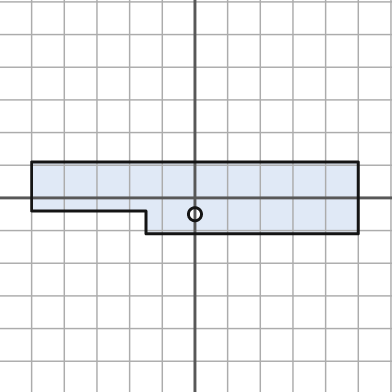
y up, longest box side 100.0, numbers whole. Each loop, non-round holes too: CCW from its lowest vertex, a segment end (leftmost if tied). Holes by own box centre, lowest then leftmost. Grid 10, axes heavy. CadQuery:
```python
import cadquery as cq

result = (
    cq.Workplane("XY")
    .moveTo(-15.0, -11.0)
    .lineTo(50.0, -11.0)
    .lineTo(50.0, 11.0)
    .lineTo(-50.0, 11.0)
    .lineTo(-50.0, -4.0)
    .lineTo(-15.0, -4.0)
    .close()
    .moveTo(0.0, -5.0)
    .circle(2.0)
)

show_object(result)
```